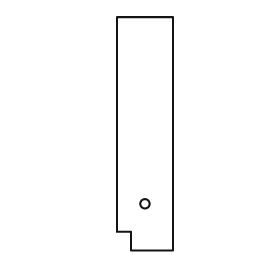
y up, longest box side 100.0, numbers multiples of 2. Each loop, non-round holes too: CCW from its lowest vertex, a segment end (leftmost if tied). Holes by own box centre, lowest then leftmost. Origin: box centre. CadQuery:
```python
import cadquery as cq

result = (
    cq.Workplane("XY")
    .moveTo(-6.0, -50.0)
    .lineTo(12.0, -50.0)
    .lineTo(12.0, 50.0)
    .lineTo(-12.0, 50.0)
    .lineTo(-12.0, -42.0)
    .lineTo(-6.0, -42.0)
    .close()
    .moveTo(0.0, -30.0)
    .circle(2.0)
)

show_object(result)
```